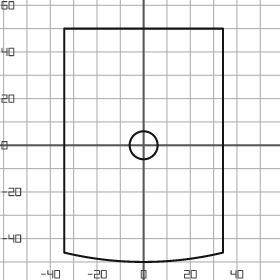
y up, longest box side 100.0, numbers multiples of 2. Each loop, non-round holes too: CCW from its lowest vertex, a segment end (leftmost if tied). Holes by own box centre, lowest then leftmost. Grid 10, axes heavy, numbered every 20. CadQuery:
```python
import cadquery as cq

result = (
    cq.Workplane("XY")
    .moveTo(-34.0, -46.0)
    .threePointArc((0.0, -50.0), (34.0, -46.0))
    .lineTo(34.0, 50.0)
    .lineTo(-34.0, 50.0)
    .close()
    .moveTo(0.0, 0.0)
    .circle(6.0)
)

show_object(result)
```